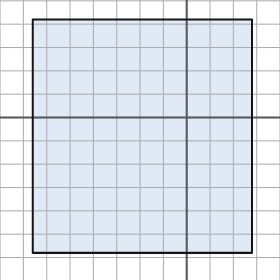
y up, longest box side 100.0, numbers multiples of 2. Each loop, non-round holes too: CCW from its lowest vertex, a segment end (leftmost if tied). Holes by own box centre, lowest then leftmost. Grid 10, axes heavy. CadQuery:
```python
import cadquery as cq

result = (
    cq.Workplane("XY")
    .moveTo(-66.0, -58.0)
    .lineTo(28.0, -58.0)
    .lineTo(28.0, 42.0)
    .lineTo(-66.0, 42.0)
    .close()
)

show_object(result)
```